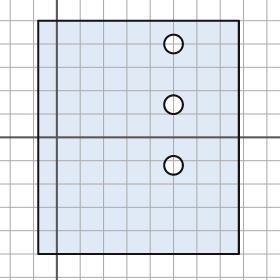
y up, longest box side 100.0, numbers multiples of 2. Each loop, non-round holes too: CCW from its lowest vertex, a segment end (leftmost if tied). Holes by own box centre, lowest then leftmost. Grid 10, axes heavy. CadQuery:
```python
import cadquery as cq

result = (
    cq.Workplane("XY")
    .moveTo(-8.0, -50.0)
    .lineTo(78.0, -50.0)
    .lineTo(78.0, 50.0)
    .lineTo(-8.0, 50.0)
    .close()
    .moveTo(50.0, -12.0)
    .circle(4.0)
    .moveTo(50.0, 14.0)
    .circle(4.0)
    .moveTo(50.0, 40.0)
    .circle(4.0)
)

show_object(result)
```